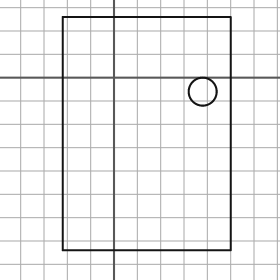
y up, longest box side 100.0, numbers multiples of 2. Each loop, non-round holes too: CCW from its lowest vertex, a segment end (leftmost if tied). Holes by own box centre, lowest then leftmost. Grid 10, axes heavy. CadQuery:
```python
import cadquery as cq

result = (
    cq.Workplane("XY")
    .moveTo(-22.0, -74.0)
    .lineTo(50.0, -74.0)
    .lineTo(50.0, 26.0)
    .lineTo(-22.0, 26.0)
    .close()
    .moveTo(38.0, -6.0)
    .circle(6.0)
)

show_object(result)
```